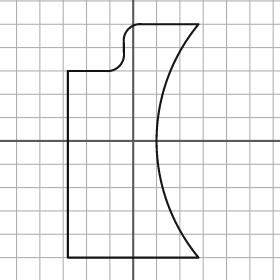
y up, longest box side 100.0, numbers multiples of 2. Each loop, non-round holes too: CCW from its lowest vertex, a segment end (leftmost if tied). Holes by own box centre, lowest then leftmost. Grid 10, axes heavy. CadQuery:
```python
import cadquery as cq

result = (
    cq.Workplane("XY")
    .moveTo(-28.0, -50.0)
    .lineTo(28.0, -50.0)
    .threePointArc((10.0, 0.0), (28.0, 50.0))
    .lineTo(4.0, 50.0)
    .threePointArc((-2.0, 48.0), (-4.0, 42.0))
    .lineTo(-4.0, 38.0)
    .threePointArc((-6.0, 32.0), (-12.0, 30.0))
    .lineTo(-28.0, 30.0)
    .close()
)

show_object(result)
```